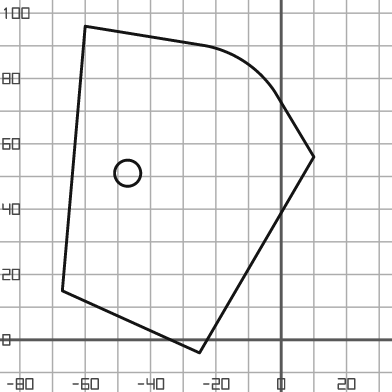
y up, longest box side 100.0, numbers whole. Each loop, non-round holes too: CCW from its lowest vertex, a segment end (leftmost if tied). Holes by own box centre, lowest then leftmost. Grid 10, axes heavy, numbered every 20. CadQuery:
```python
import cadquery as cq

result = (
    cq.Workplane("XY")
    .moveTo(-25.0, -4.0)
    .lineTo(10.0, 56.0)
    .lineTo(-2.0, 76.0)
    .threePointArc((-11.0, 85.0), (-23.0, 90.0))
    .lineTo(-60.0, 96.0)
    .lineTo(-67.0, 15.0)
    .close()
    .moveTo(-47.0, 51.0)
    .circle(4.0)
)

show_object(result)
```